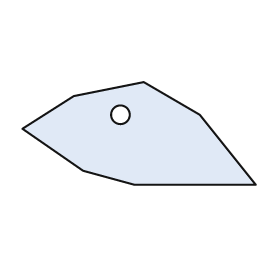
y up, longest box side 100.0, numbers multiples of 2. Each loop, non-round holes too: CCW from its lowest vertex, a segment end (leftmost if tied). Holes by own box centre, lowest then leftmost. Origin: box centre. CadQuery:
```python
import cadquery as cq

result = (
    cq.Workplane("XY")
    .moveTo(-2.0, -22.0)
    .lineTo(50.0, -22.0)
    .lineTo(26.0, 8.0)
    .lineTo(2.0, 22.0)
    .lineTo(-28.0, 16.0)
    .lineTo(-50.0, 2.0)
    .lineTo(-24.0, -16.0)
    .close()
    .moveTo(-8.0, 8.0)
    .circle(4.0)
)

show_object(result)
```